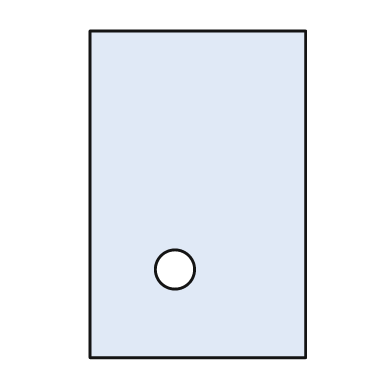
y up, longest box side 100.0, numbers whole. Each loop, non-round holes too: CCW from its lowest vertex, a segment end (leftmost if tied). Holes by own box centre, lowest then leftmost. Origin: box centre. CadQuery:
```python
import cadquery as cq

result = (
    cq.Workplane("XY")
    .moveTo(-33.0, -50.0)
    .lineTo(33.0, -50.0)
    .lineTo(33.0, 50.0)
    .lineTo(-33.0, 50.0)
    .close()
    .moveTo(-7.0, -23.0)
    .circle(6.0)
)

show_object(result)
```